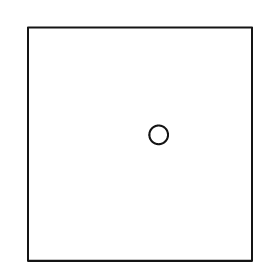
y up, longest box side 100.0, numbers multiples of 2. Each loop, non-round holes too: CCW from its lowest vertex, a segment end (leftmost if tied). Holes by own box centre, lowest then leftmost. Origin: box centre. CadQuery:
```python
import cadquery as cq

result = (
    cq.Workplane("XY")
    .moveTo(-48.0, -50.0)
    .lineTo(48.0, -50.0)
    .lineTo(48.0, 50.0)
    .lineTo(-48.0, 50.0)
    .close()
    .moveTo(8.0, 4.0)
    .circle(4.0)
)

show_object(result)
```